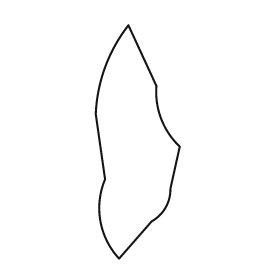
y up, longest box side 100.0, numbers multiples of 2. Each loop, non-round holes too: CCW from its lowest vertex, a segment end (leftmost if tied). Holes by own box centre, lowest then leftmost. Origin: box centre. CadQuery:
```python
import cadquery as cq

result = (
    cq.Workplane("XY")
    .moveTo(-8.0, -50.0)
    .lineTo(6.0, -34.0)
    .threePointArc((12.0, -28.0), (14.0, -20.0))
    .lineTo(18.0, -2.0)
    .threePointArc((10.0, 10.0), (8.0, 24.0))
    .lineTo(-4.0, 50.0)
    .threePointArc((-14.0, 32.0), (-18.0, 12.0))
    .lineTo(-14.0, -16.0)
    .threePointArc((-16.0, -34.0), (-8.0, -50.0))
    .close()
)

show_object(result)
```